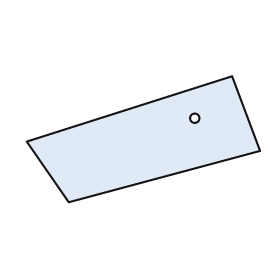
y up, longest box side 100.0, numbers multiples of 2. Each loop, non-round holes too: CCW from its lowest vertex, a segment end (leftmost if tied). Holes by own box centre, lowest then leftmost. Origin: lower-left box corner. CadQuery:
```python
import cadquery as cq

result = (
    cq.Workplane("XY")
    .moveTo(18.0, 0.0)
    .lineTo(100.0, 22.0)
    .lineTo(88.0, 54.0)
    .lineTo(0.0, 26.0)
    .close()
    .moveTo(72.0, 36.0)
    .circle(2.0)
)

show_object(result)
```